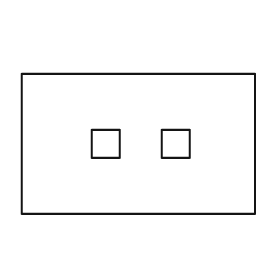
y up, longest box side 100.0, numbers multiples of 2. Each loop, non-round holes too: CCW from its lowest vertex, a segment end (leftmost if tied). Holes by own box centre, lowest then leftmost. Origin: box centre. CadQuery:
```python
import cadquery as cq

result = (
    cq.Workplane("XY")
    .moveTo(-50.0, -30.0)
    .lineTo(50.0, -30.0)
    .lineTo(50.0, 30.0)
    .lineTo(-50.0, 30.0)
    .close()
    .moveTo(-20.0, -6.0)
    .lineTo(-8.0, -6.0)
    .lineTo(-8.0, 6.0)
    .lineTo(-20.0, 6.0)
    .close()
    .moveTo(10.0, -6.0)
    .lineTo(22.0, -6.0)
    .lineTo(22.0, 6.0)
    .lineTo(10.0, 6.0)
    .close()
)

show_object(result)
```